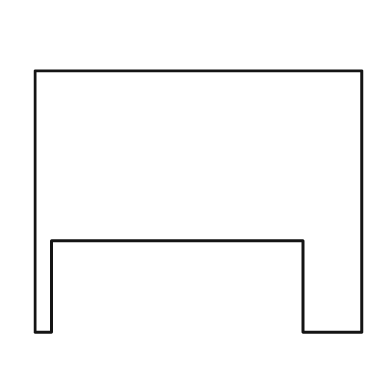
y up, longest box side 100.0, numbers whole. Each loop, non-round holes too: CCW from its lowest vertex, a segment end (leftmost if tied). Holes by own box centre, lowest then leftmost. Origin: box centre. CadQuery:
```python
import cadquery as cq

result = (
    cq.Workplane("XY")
    .moveTo(-50.0, -40.0)
    .lineTo(-45.0, -40.0)
    .lineTo(-45.0, -12.0)
    .lineTo(32.0, -12.0)
    .lineTo(32.0, -40.0)
    .lineTo(50.0, -40.0)
    .lineTo(50.0, 40.0)
    .lineTo(-50.0, 40.0)
    .close()
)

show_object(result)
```